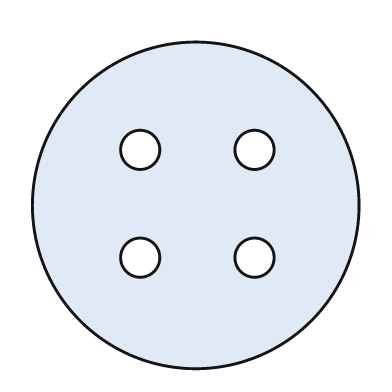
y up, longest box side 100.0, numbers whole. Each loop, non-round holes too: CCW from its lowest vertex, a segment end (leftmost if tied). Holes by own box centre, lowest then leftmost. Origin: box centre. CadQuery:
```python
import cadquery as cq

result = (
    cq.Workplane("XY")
    .moveTo(0.0, 0.0)
    .circle(50.0)
    .moveTo(-17.0, -16.0)
    .circle(6.0)
    .moveTo(18.0, -16.0)
    .circle(6.0)
    .moveTo(-17.0, 17.0)
    .circle(6.0)
    .moveTo(18.0, 17.0)
    .circle(6.0)
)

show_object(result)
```